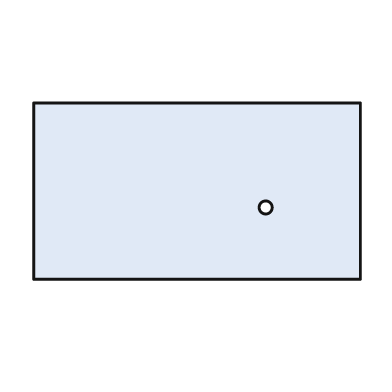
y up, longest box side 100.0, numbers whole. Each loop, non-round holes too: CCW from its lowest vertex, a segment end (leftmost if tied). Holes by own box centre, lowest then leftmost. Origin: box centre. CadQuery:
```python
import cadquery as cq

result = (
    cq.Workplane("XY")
    .moveTo(-50.0, -27.0)
    .lineTo(50.0, -27.0)
    .lineTo(50.0, 27.0)
    .lineTo(-50.0, 27.0)
    .close()
    .moveTo(21.0, -5.0)
    .circle(2.0)
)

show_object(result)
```